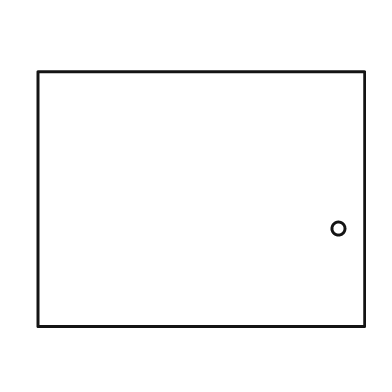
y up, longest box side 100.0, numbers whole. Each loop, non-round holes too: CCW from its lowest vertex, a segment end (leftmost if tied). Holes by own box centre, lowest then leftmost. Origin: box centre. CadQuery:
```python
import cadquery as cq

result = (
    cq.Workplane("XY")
    .moveTo(-50.0, -39.0)
    .lineTo(50.0, -39.0)
    .lineTo(50.0, 39.0)
    .lineTo(-50.0, 39.0)
    .close()
    .moveTo(42.0, -9.0)
    .circle(2.0)
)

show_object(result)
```